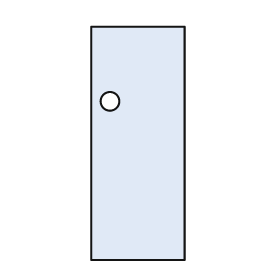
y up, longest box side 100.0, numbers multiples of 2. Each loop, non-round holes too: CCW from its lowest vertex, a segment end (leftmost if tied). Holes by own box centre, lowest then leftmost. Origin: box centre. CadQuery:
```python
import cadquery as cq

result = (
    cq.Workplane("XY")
    .moveTo(-20.0, -50.0)
    .lineTo(20.0, -50.0)
    .lineTo(20.0, 50.0)
    .lineTo(-20.0, 50.0)
    .close()
    .moveTo(-12.0, 18.0)
    .circle(4.0)
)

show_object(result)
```